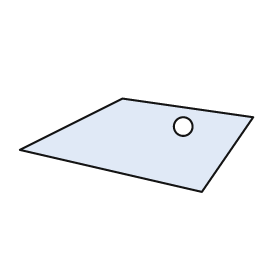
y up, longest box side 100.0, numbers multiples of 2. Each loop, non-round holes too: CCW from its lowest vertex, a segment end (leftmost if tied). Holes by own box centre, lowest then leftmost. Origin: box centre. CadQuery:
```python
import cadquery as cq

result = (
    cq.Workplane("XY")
    .moveTo(28.0, -20.0)
    .lineTo(50.0, 12.0)
    .lineTo(-6.0, 20.0)
    .lineTo(-50.0, -2.0)
    .close()
    .moveTo(20.0, 8.0)
    .circle(4.0)
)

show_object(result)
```